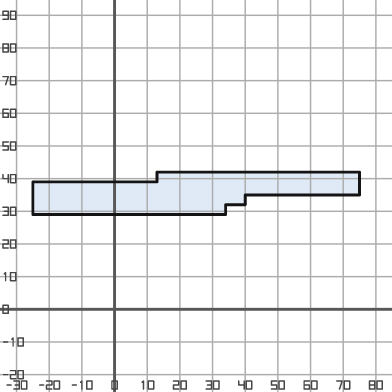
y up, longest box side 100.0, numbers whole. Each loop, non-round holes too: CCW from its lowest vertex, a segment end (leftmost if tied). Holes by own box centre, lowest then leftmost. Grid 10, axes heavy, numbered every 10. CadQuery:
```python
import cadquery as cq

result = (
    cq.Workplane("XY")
    .moveTo(-25.0, 29.0)
    .lineTo(34.0, 29.0)
    .lineTo(34.0, 32.0)
    .lineTo(40.0, 32.0)
    .lineTo(40.0, 35.0)
    .lineTo(75.0, 35.0)
    .lineTo(75.0, 42.0)
    .lineTo(13.0, 42.0)
    .lineTo(13.0, 39.0)
    .lineTo(-25.0, 39.0)
    .close()
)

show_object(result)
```